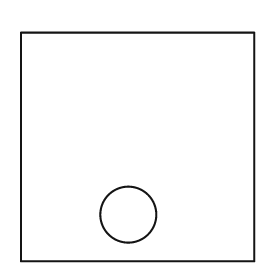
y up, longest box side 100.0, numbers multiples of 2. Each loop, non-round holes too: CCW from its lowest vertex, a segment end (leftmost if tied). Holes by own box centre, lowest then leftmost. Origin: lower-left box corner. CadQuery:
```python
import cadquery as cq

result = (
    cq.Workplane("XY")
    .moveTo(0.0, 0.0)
    .lineTo(100.0, 0.0)
    .lineTo(100.0, 98.0)
    .lineTo(0.0, 98.0)
    .close()
    .moveTo(46.0, 20.0)
    .circle(12.0)
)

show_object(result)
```